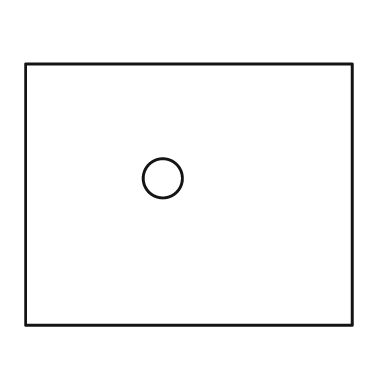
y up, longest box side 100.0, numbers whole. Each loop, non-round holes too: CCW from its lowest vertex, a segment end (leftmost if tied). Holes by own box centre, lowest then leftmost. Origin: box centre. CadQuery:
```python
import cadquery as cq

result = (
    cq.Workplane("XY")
    .moveTo(-50.0, -40.0)
    .lineTo(50.0, -40.0)
    .lineTo(50.0, 40.0)
    .lineTo(-50.0, 40.0)
    .close()
    .moveTo(-8.0, 5.0)
    .circle(6.0)
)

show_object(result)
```